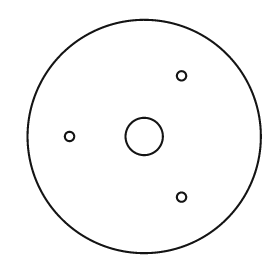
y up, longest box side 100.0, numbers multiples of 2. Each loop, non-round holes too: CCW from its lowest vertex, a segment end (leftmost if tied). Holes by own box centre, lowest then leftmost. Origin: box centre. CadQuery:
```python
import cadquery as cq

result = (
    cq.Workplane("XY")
    .moveTo(0.0, 0.0)
    .circle(50.0)
    .moveTo(16.0, -26.0)
    .circle(2.0)
    .moveTo(-32.0, 0.0)
    .circle(2.0)
    .moveTo(0.0, 0.0)
    .circle(8.0)
    .moveTo(16.0, 26.0)
    .circle(2.0)
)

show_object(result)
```